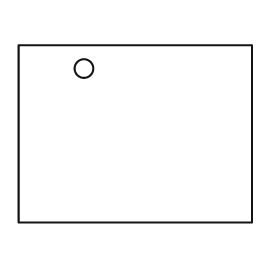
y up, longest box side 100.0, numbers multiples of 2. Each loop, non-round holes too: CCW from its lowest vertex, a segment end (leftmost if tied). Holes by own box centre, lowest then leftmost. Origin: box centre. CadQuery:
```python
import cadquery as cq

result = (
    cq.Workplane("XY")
    .moveTo(-50.0, -38.0)
    .lineTo(50.0, -38.0)
    .lineTo(50.0, 38.0)
    .lineTo(-50.0, 38.0)
    .close()
    .moveTo(-22.0, 28.0)
    .circle(4.0)
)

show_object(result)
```